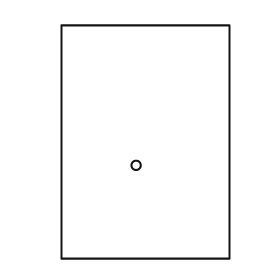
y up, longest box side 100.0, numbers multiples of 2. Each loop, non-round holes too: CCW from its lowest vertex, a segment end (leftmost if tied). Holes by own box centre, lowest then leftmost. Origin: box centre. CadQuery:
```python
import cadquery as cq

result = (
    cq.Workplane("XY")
    .moveTo(-36.0, -50.0)
    .lineTo(36.0, -50.0)
    .lineTo(36.0, 50.0)
    .lineTo(-36.0, 50.0)
    .close()
    .moveTo(-4.0, -10.0)
    .circle(2.0)
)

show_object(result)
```